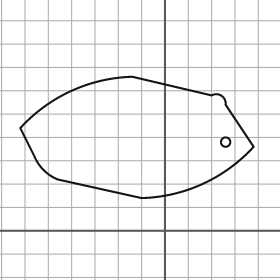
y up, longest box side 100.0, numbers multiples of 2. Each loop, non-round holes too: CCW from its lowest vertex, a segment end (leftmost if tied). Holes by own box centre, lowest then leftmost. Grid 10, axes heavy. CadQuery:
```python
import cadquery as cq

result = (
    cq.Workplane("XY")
    .moveTo(-10.0, 14.0)
    .threePointArc((16.0, 20.0), (38.0, 36.0))
    .lineTo(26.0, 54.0)
    .threePointArc((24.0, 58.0), (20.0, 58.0))
    .lineTo(-14.0, 66.0)
    .threePointArc((-40.0, 60.0), (-62.0, 44.0))
    .lineTo(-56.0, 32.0)
    .threePointArc((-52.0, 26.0), (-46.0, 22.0))
    .close()
    .moveTo(26.0, 38.0)
    .circle(2.0)
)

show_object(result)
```